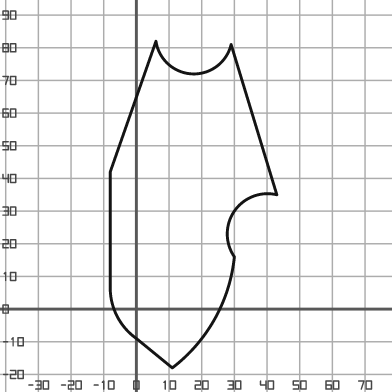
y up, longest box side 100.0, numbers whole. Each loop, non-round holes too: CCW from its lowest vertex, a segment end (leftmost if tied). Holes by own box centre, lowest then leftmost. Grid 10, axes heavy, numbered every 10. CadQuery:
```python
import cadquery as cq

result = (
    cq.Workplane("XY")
    .moveTo(11.0, -18.0)
    .threePointArc((24.0, -3.0), (30.0, 16.0))
    .threePointArc((30.0, 30.0), (43.0, 35.0))
    .lineTo(29.0, 81.0)
    .threePointArc((17.0, 72.0), (6.0, 82.0))
    .lineTo(-8.0, 42.0)
    .lineTo(-8.0, 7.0)
    .threePointArc((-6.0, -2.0), (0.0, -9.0))
    .close()
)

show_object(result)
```